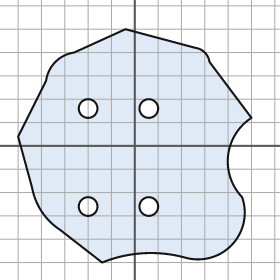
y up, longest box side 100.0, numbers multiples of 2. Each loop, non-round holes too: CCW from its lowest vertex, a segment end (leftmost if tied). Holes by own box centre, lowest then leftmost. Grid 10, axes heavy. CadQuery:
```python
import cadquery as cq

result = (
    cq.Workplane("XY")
    .moveTo(-14.0, -50.0)
    .threePointArc((4.0, -46.0), (22.0, -48.0))
    .threePointArc((42.0, -42.0), (46.0, -22.0))
    .threePointArc((40.0, -4.0), (50.0, 12.0))
    .lineTo(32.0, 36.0)
    .threePointArc((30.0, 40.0), (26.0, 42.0))
    .lineTo(-4.0, 50.0)
    .lineTo(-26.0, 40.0)
    .threePointArc((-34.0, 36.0), (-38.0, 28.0))
    .lineTo(-50.0, 4.0)
    .lineTo(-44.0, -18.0)
    .threePointArc((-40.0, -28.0), (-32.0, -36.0))
    .close()
    .moveTo(-20.0, -26.0)
    .circle(4.0)
    .moveTo(6.0, -26.0)
    .circle(4.0)
    .moveTo(-20.0, 16.0)
    .circle(4.0)
    .moveTo(6.0, 16.0)
    .circle(4.0)
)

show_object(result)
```